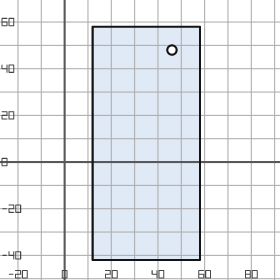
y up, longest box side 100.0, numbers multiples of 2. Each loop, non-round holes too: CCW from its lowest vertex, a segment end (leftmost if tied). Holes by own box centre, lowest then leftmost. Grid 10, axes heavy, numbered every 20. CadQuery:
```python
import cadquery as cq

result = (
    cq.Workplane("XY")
    .moveTo(12.0, -42.0)
    .lineTo(58.0, -42.0)
    .lineTo(58.0, 58.0)
    .lineTo(12.0, 58.0)
    .close()
    .moveTo(46.0, 48.0)
    .circle(2.0)
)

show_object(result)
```